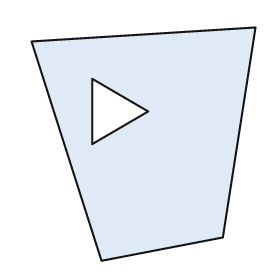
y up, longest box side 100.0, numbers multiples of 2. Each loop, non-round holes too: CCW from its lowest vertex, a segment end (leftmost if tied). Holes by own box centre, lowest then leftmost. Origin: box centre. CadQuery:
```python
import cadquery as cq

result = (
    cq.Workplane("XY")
    .moveTo(-18.0, -50.0)
    .lineTo(34.0, -40.0)
    .lineTo(48.0, 50.0)
    .lineTo(-48.0, 44.0)
    .close()
    .moveTo(-22.0, 0.0)
    .lineTo(2.0, 14.0)
    .lineTo(-22.0, 28.0)
    .close()
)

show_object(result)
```